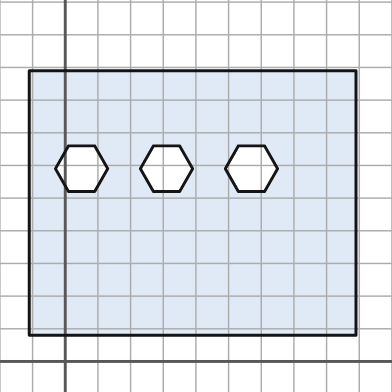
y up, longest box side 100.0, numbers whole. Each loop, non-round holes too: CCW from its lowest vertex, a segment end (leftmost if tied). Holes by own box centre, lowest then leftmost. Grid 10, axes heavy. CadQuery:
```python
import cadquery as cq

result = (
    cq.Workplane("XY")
    .moveTo(-11.0, 8.0)
    .lineTo(89.0, 8.0)
    .lineTo(89.0, 89.0)
    .lineTo(-11.0, 89.0)
    .close()
    .moveTo(1.0, 52.0)
    .lineTo(9.0, 52.0)
    .lineTo(13.0, 59.0)
    .lineTo(9.0, 66.0)
    .lineTo(1.0, 66.0)
    .lineTo(-3.0, 59.0)
    .close()
    .moveTo(27.0, 52.0)
    .lineTo(35.0, 52.0)
    .lineTo(39.0, 59.0)
    .lineTo(35.0, 66.0)
    .lineTo(27.0, 66.0)
    .lineTo(23.0, 59.0)
    .close()
    .moveTo(53.0, 52.0)
    .lineTo(61.0, 52.0)
    .lineTo(65.0, 59.0)
    .lineTo(61.0, 66.0)
    .lineTo(53.0, 66.0)
    .lineTo(49.0, 59.0)
    .close()
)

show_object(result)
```